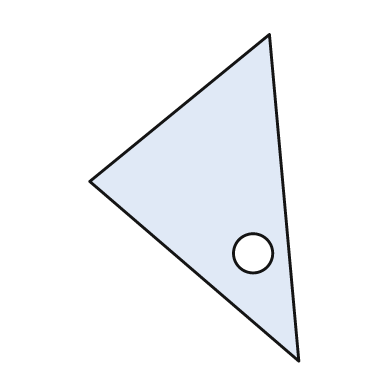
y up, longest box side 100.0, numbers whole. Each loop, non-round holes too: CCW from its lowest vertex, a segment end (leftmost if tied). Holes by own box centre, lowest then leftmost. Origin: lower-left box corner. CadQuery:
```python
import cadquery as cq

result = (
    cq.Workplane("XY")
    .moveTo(64.0, 0.0)
    .lineTo(55.0, 100.0)
    .lineTo(0.0, 55.0)
    .close()
    .moveTo(50.0, 33.0)
    .circle(6.0)
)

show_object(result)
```